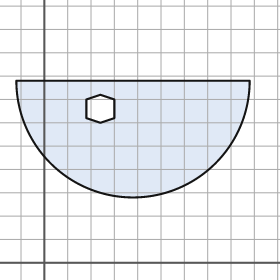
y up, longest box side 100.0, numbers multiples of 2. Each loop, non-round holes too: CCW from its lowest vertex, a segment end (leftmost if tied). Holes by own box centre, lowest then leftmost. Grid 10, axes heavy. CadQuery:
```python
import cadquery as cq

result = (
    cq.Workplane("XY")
    .moveTo(-12.0, 78.0)
    .threePointArc((38.0, 28.0), (88.0, 78.0))
    .close()
    .moveTo(24.0, 60.0)
    .lineTo(30.0, 62.0)
    .lineTo(30.0, 70.0)
    .lineTo(24.0, 72.0)
    .lineTo(18.0, 70.0)
    .lineTo(18.0, 62.0)
    .close()
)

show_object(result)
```